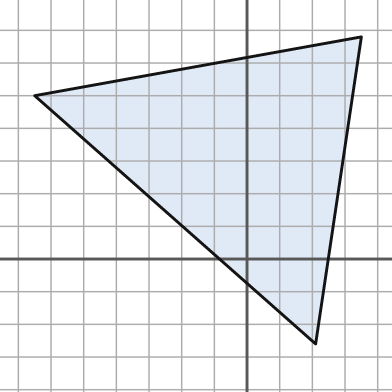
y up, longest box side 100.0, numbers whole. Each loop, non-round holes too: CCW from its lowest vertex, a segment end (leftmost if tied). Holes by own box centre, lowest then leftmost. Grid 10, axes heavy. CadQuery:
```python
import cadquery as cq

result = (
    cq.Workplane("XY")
    .moveTo(21.0, -26.0)
    .lineTo(35.0, 68.0)
    .lineTo(-65.0, 50.0)
    .close()
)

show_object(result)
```